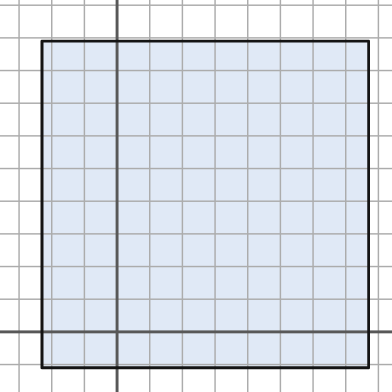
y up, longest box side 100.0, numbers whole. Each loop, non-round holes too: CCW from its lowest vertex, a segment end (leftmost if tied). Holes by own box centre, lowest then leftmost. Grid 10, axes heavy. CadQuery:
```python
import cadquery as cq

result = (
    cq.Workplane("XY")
    .moveTo(-23.0, -11.0)
    .lineTo(77.0, -11.0)
    .lineTo(77.0, 89.0)
    .lineTo(-23.0, 89.0)
    .close()
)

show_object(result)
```